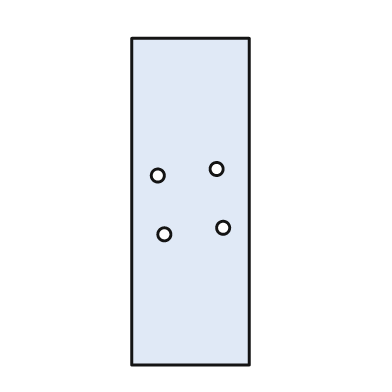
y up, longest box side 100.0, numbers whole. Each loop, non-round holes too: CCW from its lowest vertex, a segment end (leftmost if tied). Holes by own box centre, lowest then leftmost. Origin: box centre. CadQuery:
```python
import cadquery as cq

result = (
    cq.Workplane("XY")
    .moveTo(-18.0, -50.0)
    .lineTo(18.0, -50.0)
    .lineTo(18.0, 50.0)
    .lineTo(-18.0, 50.0)
    .close()
    .moveTo(-8.0, -10.0)
    .circle(2.0)
    .moveTo(10.0, -8.0)
    .circle(2.0)
    .moveTo(-10.0, 8.0)
    .circle(2.0)
    .moveTo(8.0, 10.0)
    .circle(2.0)
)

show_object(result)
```